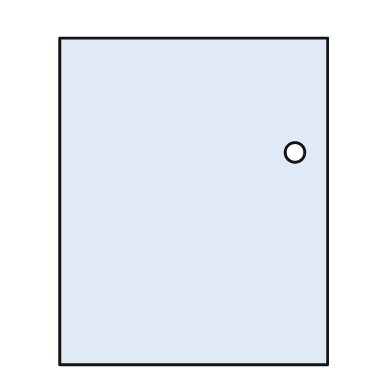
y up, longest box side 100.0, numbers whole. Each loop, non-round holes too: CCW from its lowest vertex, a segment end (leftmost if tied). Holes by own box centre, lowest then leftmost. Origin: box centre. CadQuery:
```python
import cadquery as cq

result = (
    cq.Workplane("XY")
    .moveTo(-41.0, -50.0)
    .lineTo(41.0, -50.0)
    .lineTo(41.0, 50.0)
    .lineTo(-41.0, 50.0)
    .close()
    .moveTo(31.0, 15.0)
    .circle(3.0)
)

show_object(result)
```